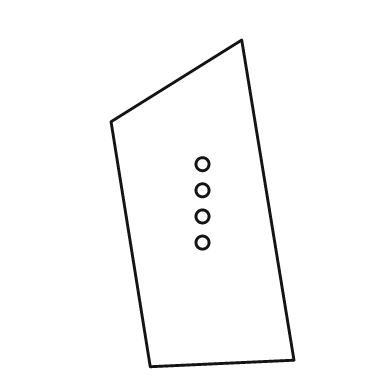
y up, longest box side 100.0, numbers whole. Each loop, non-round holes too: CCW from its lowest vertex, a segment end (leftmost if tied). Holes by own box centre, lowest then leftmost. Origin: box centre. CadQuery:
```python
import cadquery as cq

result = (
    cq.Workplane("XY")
    .moveTo(-16.0, -50.0)
    .lineTo(28.0, -48.0)
    .lineTo(12.0, 50.0)
    .lineTo(-28.0, 25.0)
    .close()
    .moveTo(0.0, -12.0)
    .circle(2.0)
    .moveTo(0.0, -4.0)
    .circle(2.0)
    .moveTo(0.0, 4.0)
    .circle(2.0)
    .moveTo(0.0, 12.0)
    .circle(2.0)
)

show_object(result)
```